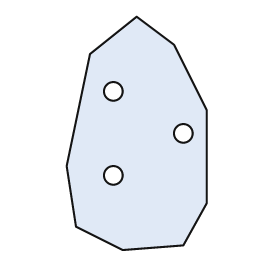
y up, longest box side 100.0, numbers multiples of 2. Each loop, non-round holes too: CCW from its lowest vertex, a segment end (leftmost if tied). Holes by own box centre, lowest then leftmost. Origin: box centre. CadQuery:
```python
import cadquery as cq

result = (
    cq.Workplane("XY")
    .moveTo(-6.0, -50.0)
    .lineTo(20.0, -48.0)
    .lineTo(30.0, -30.0)
    .lineTo(30.0, 10.0)
    .lineTo(16.0, 38.0)
    .lineTo(0.0, 50.0)
    .lineTo(-20.0, 34.0)
    .lineTo(-30.0, -14.0)
    .lineTo(-26.0, -40.0)
    .close()
    .moveTo(-10.0, -18.0)
    .circle(4.0)
    .moveTo(20.0, 0.0)
    .circle(4.0)
    .moveTo(-10.0, 18.0)
    .circle(4.0)
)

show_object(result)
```